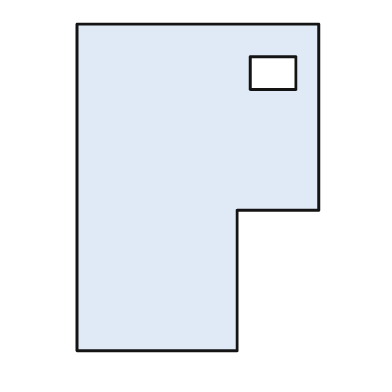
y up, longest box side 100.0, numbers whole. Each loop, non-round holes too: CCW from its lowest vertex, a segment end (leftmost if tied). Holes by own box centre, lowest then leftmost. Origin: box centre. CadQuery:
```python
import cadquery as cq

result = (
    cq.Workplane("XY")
    .moveTo(-37.0, -50.0)
    .lineTo(12.0, -50.0)
    .lineTo(12.0, -7.0)
    .lineTo(37.0, -7.0)
    .lineTo(37.0, 50.0)
    .lineTo(-37.0, 50.0)
    .close()
    .moveTo(16.0, 30.0)
    .lineTo(30.0, 30.0)
    .lineTo(30.0, 40.0)
    .lineTo(16.0, 40.0)
    .close()
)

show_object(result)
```